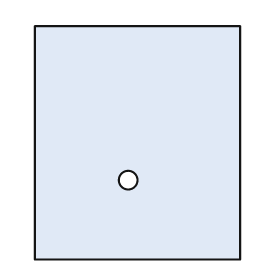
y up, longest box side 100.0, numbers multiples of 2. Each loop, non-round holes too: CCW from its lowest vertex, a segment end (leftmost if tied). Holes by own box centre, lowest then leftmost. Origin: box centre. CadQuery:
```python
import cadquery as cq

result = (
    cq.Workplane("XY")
    .moveTo(-44.0, -50.0)
    .lineTo(44.0, -50.0)
    .lineTo(44.0, 50.0)
    .lineTo(-44.0, 50.0)
    .close()
    .moveTo(-4.0, -16.0)
    .circle(4.0)
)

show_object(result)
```